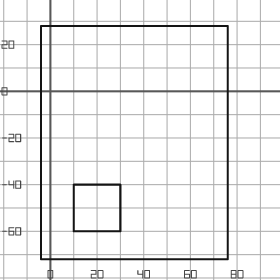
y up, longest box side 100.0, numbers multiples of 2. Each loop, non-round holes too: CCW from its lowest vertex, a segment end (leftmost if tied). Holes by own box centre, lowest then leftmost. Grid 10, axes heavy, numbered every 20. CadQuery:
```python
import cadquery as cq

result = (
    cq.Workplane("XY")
    .moveTo(-4.0, -72.0)
    .lineTo(76.0, -72.0)
    .lineTo(76.0, 28.0)
    .lineTo(-4.0, 28.0)
    .close()
    .moveTo(10.0, -60.0)
    .lineTo(30.0, -60.0)
    .lineTo(30.0, -40.0)
    .lineTo(10.0, -40.0)
    .close()
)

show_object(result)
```